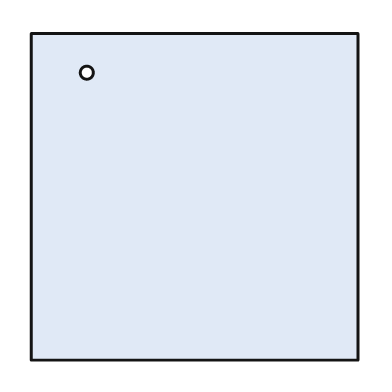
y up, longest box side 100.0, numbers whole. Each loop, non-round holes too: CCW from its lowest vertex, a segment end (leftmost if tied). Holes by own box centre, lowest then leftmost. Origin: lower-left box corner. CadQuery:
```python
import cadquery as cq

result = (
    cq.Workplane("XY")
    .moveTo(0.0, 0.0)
    .lineTo(100.0, 0.0)
    .lineTo(100.0, 100.0)
    .lineTo(0.0, 100.0)
    .close()
    .moveTo(17.0, 88.0)
    .circle(2.0)
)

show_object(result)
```